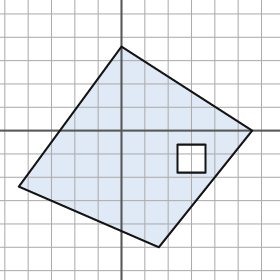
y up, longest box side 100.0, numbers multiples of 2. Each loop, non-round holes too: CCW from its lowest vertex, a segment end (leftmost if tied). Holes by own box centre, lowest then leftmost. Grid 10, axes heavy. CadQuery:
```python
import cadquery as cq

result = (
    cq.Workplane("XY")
    .moveTo(16.0, -50.0)
    .lineTo(56.0, 0.0)
    .lineTo(0.0, 36.0)
    .lineTo(-44.0, -24.0)
    .close()
    .moveTo(24.0, -18.0)
    .lineTo(36.0, -18.0)
    .lineTo(36.0, -6.0)
    .lineTo(24.0, -6.0)
    .close()
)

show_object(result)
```